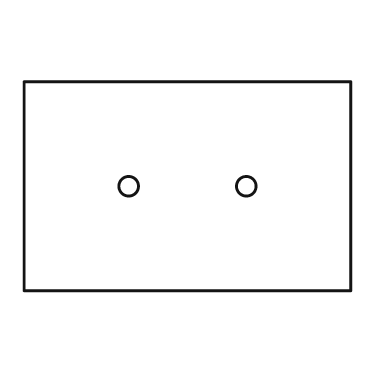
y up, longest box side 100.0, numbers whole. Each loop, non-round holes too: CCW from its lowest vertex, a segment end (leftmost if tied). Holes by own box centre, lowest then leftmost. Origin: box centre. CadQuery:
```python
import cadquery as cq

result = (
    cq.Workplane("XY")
    .moveTo(-50.0, -32.0)
    .lineTo(50.0, -32.0)
    .lineTo(50.0, 32.0)
    .lineTo(-50.0, 32.0)
    .close()
    .moveTo(-18.0, 0.0)
    .circle(3.0)
    .moveTo(18.0, 0.0)
    .circle(3.0)
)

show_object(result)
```